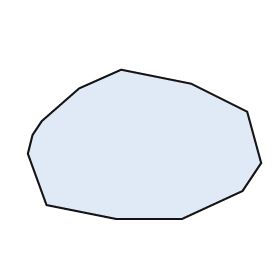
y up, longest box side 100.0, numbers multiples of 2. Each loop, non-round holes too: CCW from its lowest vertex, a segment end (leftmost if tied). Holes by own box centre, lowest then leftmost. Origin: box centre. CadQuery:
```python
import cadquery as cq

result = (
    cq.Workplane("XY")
    .moveTo(-12.0, -32.0)
    .lineTo(16.0, -32.0)
    .lineTo(42.0, -20.0)
    .lineTo(50.0, -8.0)
    .lineTo(44.0, 14.0)
    .lineTo(20.0, 26.0)
    .lineTo(-10.0, 32.0)
    .lineTo(-28.0, 24.0)
    .lineTo(-44.0, 10.0)
    .lineTo(-48.0, 4.0)
    .lineTo(-50.0, -4.0)
    .lineTo(-42.0, -26.0)
    .close()
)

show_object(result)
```